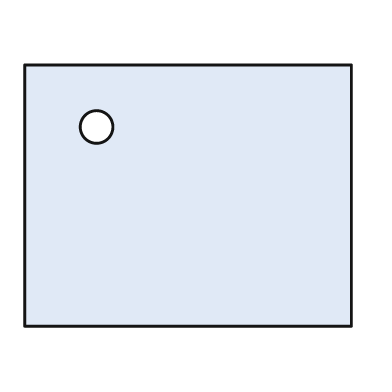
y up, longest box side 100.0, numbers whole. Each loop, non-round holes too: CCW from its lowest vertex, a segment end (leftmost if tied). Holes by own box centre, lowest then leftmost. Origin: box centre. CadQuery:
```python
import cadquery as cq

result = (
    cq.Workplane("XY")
    .moveTo(-50.0, -40.0)
    .lineTo(50.0, -40.0)
    .lineTo(50.0, 40.0)
    .lineTo(-50.0, 40.0)
    .close()
    .moveTo(-28.0, 21.0)
    .circle(5.0)
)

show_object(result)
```